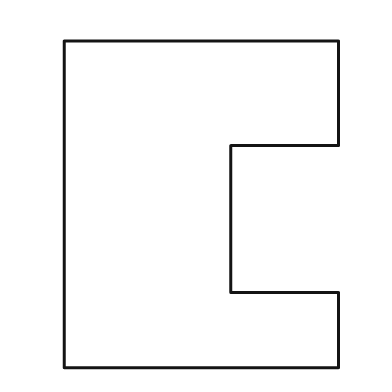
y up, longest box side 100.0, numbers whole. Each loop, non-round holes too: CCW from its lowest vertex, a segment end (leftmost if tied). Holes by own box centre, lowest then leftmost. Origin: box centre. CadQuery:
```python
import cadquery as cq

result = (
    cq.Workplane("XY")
    .moveTo(-42.0, -50.0)
    .lineTo(42.0, -50.0)
    .lineTo(42.0, -27.0)
    .lineTo(9.0, -27.0)
    .lineTo(9.0, 18.0)
    .lineTo(42.0, 18.0)
    .lineTo(42.0, 50.0)
    .lineTo(-42.0, 50.0)
    .close()
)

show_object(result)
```